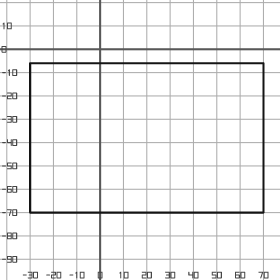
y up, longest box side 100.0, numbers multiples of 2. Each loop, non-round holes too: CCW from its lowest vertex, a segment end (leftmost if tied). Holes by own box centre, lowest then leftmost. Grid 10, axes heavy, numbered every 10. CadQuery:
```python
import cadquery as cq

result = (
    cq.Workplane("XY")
    .moveTo(-30.0, -70.0)
    .lineTo(70.0, -70.0)
    .lineTo(70.0, -6.0)
    .lineTo(-30.0, -6.0)
    .close()
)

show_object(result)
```